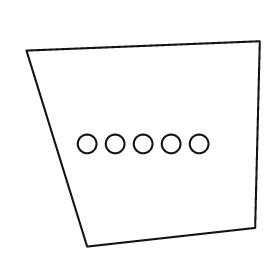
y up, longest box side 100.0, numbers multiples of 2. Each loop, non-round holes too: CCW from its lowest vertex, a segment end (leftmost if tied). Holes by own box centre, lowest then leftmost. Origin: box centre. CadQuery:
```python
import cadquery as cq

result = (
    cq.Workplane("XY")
    .moveTo(-24.0, -44.0)
    .lineTo(48.0, -36.0)
    .lineTo(50.0, 44.0)
    .lineTo(-50.0, 40.0)
    .close()
    .moveTo(-24.0, 0.0)
    .circle(4.0)
    .moveTo(-12.0, 0.0)
    .circle(4.0)
    .moveTo(0.0, 0.0)
    .circle(4.0)
    .moveTo(12.0, 0.0)
    .circle(4.0)
    .moveTo(24.0, 0.0)
    .circle(4.0)
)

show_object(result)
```